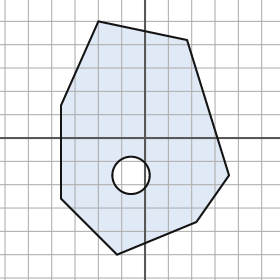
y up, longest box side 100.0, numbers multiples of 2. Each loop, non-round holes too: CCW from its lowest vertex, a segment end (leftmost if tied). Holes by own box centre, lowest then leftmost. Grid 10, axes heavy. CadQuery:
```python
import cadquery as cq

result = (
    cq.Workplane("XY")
    .moveTo(-12.0, -50.0)
    .lineTo(22.0, -36.0)
    .lineTo(36.0, -16.0)
    .lineTo(18.0, 42.0)
    .lineTo(-20.0, 50.0)
    .lineTo(-36.0, 14.0)
    .lineTo(-36.0, -26.0)
    .close()
    .moveTo(-6.0, -16.0)
    .circle(8.0)
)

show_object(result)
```